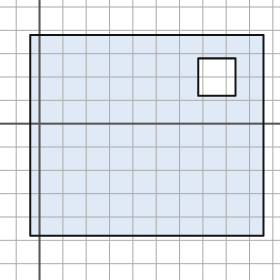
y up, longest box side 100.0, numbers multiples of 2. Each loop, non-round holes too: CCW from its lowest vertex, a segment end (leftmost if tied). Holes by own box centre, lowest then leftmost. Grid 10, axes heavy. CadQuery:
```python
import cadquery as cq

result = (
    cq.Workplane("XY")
    .moveTo(-4.0, -48.0)
    .lineTo(96.0, -48.0)
    .lineTo(96.0, 38.0)
    .lineTo(-4.0, 38.0)
    .close()
    .moveTo(68.0, 12.0)
    .lineTo(84.0, 12.0)
    .lineTo(84.0, 28.0)
    .lineTo(68.0, 28.0)
    .close()
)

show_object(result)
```